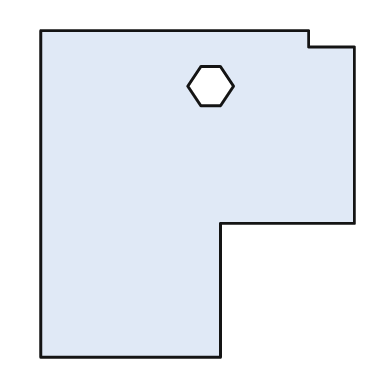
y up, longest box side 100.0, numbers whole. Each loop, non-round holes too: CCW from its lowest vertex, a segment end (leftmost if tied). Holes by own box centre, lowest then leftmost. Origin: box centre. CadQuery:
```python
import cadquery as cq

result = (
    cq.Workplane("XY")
    .moveTo(-48.0, -50.0)
    .lineTo(7.0, -50.0)
    .lineTo(7.0, -9.0)
    .lineTo(48.0, -9.0)
    .lineTo(48.0, 45.0)
    .lineTo(34.0, 45.0)
    .lineTo(34.0, 50.0)
    .lineTo(-48.0, 50.0)
    .close()
    .moveTo(1.0, 27.0)
    .lineTo(7.0, 27.0)
    .lineTo(11.0, 33.0)
    .lineTo(7.0, 39.0)
    .lineTo(1.0, 39.0)
    .lineTo(-3.0, 33.0)
    .close()
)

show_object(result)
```